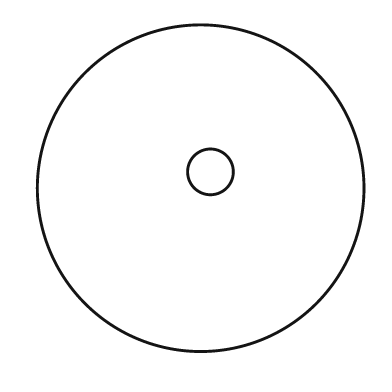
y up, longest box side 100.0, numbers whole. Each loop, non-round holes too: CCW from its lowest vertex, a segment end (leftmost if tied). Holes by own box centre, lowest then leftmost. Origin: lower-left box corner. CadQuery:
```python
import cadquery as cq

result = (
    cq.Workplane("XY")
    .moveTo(50.0, 50.0)
    .circle(50.0)
    .moveTo(53.0, 55.0)
    .circle(7.0)
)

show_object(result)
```